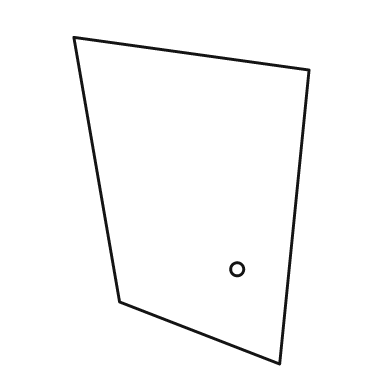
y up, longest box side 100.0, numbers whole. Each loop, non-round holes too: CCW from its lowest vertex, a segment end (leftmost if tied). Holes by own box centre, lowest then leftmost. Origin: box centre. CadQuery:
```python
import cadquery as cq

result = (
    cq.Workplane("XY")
    .moveTo(27.0, -50.0)
    .lineTo(36.0, 40.0)
    .lineTo(-36.0, 50.0)
    .lineTo(-22.0, -31.0)
    .close()
    .moveTo(14.0, -21.0)
    .circle(2.0)
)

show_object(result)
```